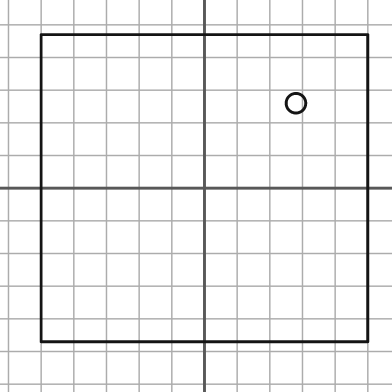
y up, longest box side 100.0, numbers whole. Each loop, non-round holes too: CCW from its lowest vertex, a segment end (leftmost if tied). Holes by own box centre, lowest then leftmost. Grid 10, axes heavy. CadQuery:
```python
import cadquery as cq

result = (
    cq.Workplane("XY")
    .moveTo(-50.0, -47.0)
    .lineTo(50.0, -47.0)
    .lineTo(50.0, 47.0)
    .lineTo(-50.0, 47.0)
    .close()
    .moveTo(28.0, 26.0)
    .circle(3.0)
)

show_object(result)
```